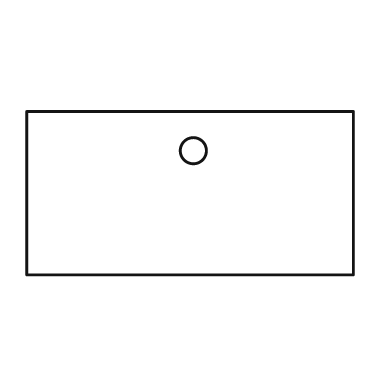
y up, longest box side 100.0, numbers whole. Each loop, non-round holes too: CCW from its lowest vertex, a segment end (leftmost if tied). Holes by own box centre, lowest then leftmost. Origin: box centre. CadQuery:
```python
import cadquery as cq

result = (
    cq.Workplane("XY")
    .moveTo(-50.0, -25.0)
    .lineTo(50.0, -25.0)
    .lineTo(50.0, 25.0)
    .lineTo(-50.0, 25.0)
    .close()
    .moveTo(1.0, 13.0)
    .circle(4.0)
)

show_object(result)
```